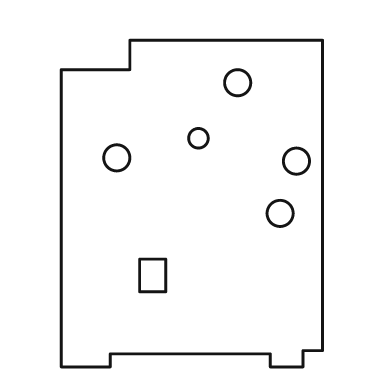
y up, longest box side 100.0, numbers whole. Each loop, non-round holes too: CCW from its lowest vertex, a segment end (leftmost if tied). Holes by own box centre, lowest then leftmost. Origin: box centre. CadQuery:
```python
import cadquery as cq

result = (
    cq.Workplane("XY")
    .moveTo(-40.0, -50.0)
    .lineTo(-25.0, -50.0)
    .lineTo(-25.0, -46.0)
    .lineTo(24.0, -46.0)
    .lineTo(24.0, -50.0)
    .lineTo(34.0, -50.0)
    .lineTo(34.0, -45.0)
    .lineTo(40.0, -45.0)
    .lineTo(40.0, 50.0)
    .lineTo(-19.0, 50.0)
    .lineTo(-19.0, 41.0)
    .lineTo(-40.0, 41.0)
    .close()
    .moveTo(-16.0, -27.0)
    .lineTo(-8.0, -27.0)
    .lineTo(-8.0, -17.0)
    .lineTo(-16.0, -17.0)
    .close()
    .moveTo(27.0, -3.0)
    .circle(4.0)
    .moveTo(32.0, 13.0)
    .circle(4.0)
    .moveTo(-23.0, 14.0)
    .circle(4.0)
    .moveTo(2.0, 20.0)
    .circle(3.0)
    .moveTo(14.0, 37.0)
    .circle(4.0)
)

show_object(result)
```